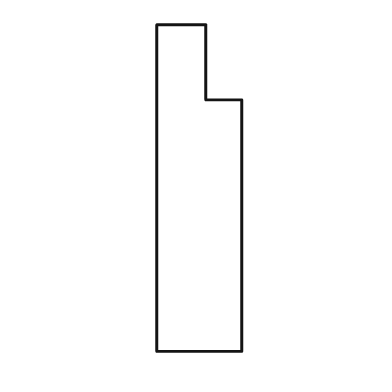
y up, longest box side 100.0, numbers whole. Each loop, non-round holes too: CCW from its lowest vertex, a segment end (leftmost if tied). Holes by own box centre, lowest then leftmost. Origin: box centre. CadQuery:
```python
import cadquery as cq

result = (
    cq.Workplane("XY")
    .moveTo(-13.0, -50.0)
    .lineTo(13.0, -50.0)
    .lineTo(13.0, 27.0)
    .lineTo(2.0, 27.0)
    .lineTo(2.0, 50.0)
    .lineTo(-13.0, 50.0)
    .close()
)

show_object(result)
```